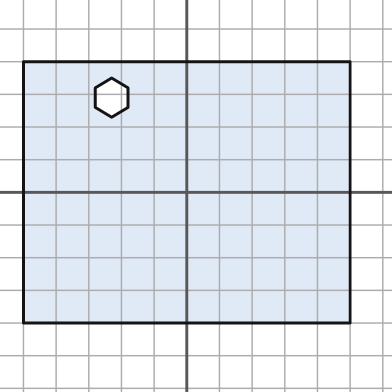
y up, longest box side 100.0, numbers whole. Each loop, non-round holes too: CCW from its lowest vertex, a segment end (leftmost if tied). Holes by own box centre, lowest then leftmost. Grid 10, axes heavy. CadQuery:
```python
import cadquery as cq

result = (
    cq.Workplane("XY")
    .moveTo(-50.0, -40.0)
    .lineTo(50.0, -40.0)
    .lineTo(50.0, 40.0)
    .lineTo(-50.0, 40.0)
    .close()
    .moveTo(-23.0, 23.0)
    .lineTo(-18.0, 26.0)
    .lineTo(-18.0, 32.0)
    .lineTo(-23.0, 35.0)
    .lineTo(-28.0, 32.0)
    .lineTo(-28.0, 26.0)
    .close()
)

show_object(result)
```